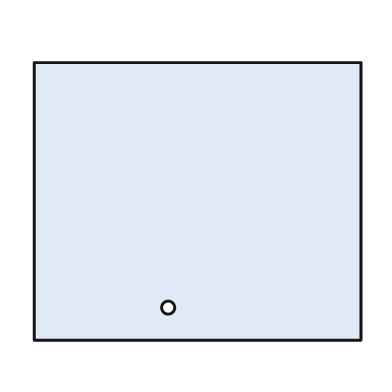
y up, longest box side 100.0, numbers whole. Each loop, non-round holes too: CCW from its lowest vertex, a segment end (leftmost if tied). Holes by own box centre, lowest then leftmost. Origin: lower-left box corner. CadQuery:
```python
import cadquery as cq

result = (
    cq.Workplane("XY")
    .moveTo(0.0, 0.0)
    .lineTo(100.0, 0.0)
    .lineTo(100.0, 85.0)
    .lineTo(0.0, 85.0)
    .close()
    .moveTo(41.0, 10.0)
    .circle(2.0)
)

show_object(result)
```